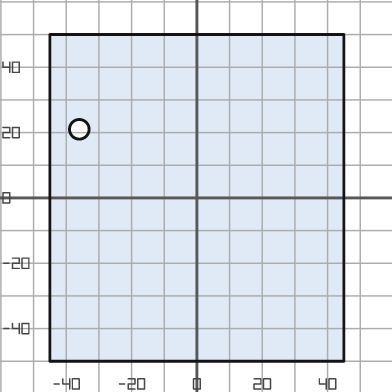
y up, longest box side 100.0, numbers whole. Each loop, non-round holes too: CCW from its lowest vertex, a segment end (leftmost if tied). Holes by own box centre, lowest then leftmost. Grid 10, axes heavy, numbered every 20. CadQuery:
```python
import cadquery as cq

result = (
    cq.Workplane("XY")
    .moveTo(-45.0, -50.0)
    .lineTo(45.0, -50.0)
    .lineTo(45.0, 50.0)
    .lineTo(-45.0, 50.0)
    .close()
    .moveTo(-36.0, 21.0)
    .circle(3.0)
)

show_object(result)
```